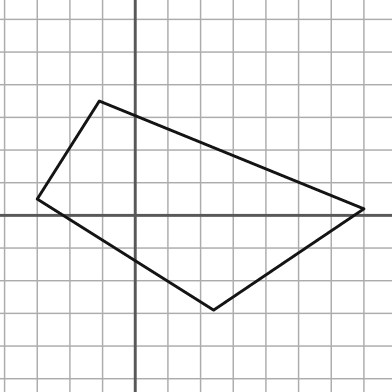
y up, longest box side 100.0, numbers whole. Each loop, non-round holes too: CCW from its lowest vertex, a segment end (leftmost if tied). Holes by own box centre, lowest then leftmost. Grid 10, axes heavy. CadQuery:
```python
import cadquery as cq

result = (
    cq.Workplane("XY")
    .moveTo(24.0, -29.0)
    .lineTo(70.0, 2.0)
    .lineTo(-11.0, 35.0)
    .lineTo(-30.0, 5.0)
    .close()
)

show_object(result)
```